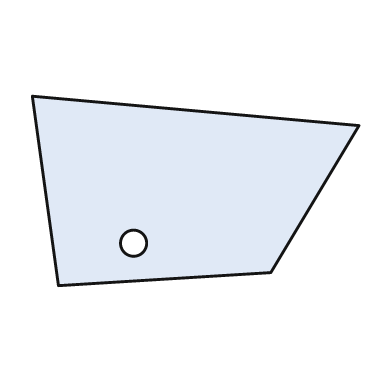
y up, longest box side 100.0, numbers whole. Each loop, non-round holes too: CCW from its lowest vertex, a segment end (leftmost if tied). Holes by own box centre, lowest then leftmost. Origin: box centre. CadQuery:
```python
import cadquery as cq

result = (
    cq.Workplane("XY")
    .moveTo(-42.0, -29.0)
    .lineTo(23.0, -25.0)
    .lineTo(50.0, 20.0)
    .lineTo(-50.0, 29.0)
    .close()
    .moveTo(-19.0, -16.0)
    .circle(4.0)
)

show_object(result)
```